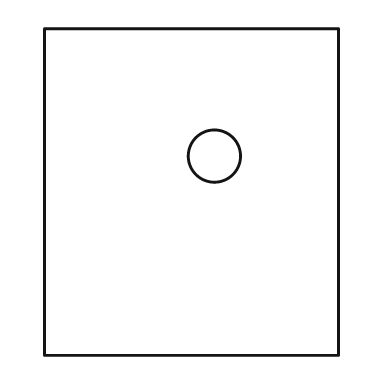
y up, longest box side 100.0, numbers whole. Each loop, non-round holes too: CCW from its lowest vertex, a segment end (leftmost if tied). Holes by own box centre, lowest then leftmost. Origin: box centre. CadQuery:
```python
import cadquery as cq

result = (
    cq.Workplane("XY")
    .moveTo(-45.0, -50.0)
    .lineTo(45.0, -50.0)
    .lineTo(45.0, 50.0)
    .lineTo(-45.0, 50.0)
    .close()
    .moveTo(7.0, 11.0)
    .circle(8.0)
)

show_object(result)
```